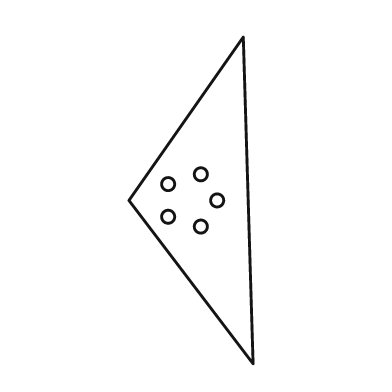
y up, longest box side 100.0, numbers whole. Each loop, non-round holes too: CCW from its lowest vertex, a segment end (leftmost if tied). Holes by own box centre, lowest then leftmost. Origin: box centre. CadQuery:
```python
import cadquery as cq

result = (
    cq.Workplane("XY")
    .moveTo(19.0, -50.0)
    .lineTo(16.0, 50.0)
    .lineTo(-19.0, 0.0)
    .close()
    .moveTo(3.0, -8.0)
    .circle(2.0)
    .moveTo(-7.0, -5.0)
    .circle(2.0)
    .moveTo(8.0, 0.0)
    .circle(2.0)
    .moveTo(-7.0, 5.0)
    .circle(2.0)
    .moveTo(3.0, 8.0)
    .circle(2.0)
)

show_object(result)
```